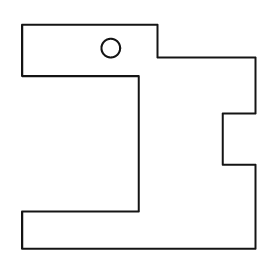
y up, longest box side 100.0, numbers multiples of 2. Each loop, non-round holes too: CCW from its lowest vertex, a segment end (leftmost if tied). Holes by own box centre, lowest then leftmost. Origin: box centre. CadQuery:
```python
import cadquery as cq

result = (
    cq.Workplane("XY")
    .moveTo(-50.0, -48.0)
    .lineTo(50.0, -48.0)
    .lineTo(50.0, -12.0)
    .lineTo(36.0, -12.0)
    .lineTo(36.0, 10.0)
    .lineTo(50.0, 10.0)
    .lineTo(50.0, 34.0)
    .lineTo(8.0, 34.0)
    .lineTo(8.0, 48.0)
    .lineTo(-50.0, 48.0)
    .lineTo(-50.0, 26.0)
    .lineTo(0.0, 26.0)
    .lineTo(0.0, -32.0)
    .lineTo(-50.0, -32.0)
    .close()
    .moveTo(-12.0, 38.0)
    .circle(4.0)
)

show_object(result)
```